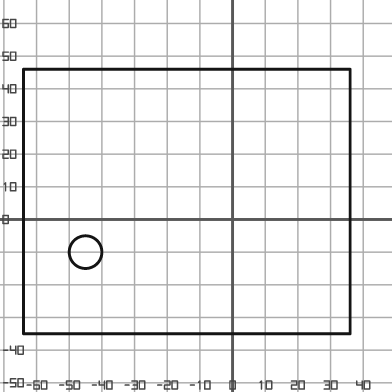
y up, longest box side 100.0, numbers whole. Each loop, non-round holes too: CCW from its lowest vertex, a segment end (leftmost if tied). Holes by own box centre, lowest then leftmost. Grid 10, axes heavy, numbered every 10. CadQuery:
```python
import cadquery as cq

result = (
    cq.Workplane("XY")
    .moveTo(-64.0, -35.0)
    .lineTo(36.0, -35.0)
    .lineTo(36.0, 46.0)
    .lineTo(-64.0, 46.0)
    .close()
    .moveTo(-45.0, -10.0)
    .circle(5.0)
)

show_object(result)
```